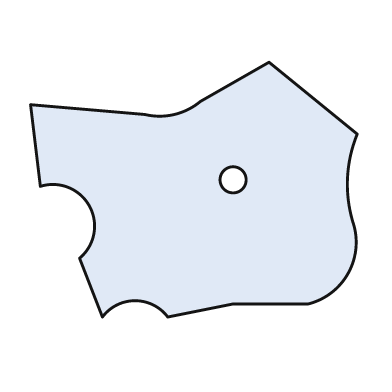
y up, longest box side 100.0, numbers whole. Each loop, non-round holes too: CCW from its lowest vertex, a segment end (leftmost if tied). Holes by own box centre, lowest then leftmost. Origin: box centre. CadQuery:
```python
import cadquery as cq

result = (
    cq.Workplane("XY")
    .moveTo(-28.0, -39.0)
    .threePointArc((-18.0, -34.0), (-8.0, -39.0))
    .lineTo(12.0, -35.0)
    .lineTo(35.0, -35.0)
    .threePointArc((47.0, -26.0), (49.0, -11.0))
    .threePointArc((47.0, 3.0), (50.0, 17.0))
    .lineTo(23.0, 39.0)
    .lineTo(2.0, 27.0)
    .threePointArc((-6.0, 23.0), (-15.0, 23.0))
    .lineTo(-50.0, 26.0)
    .lineTo(-47.0, 1.0)
    .threePointArc((-32.0, -5.0), (-35.0, -21.0))
    .close()
    .moveTo(12.0, 3.0)
    .circle(4.0)
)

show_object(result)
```